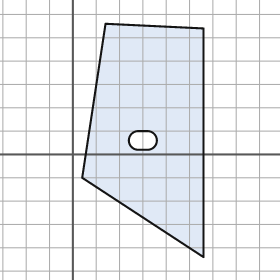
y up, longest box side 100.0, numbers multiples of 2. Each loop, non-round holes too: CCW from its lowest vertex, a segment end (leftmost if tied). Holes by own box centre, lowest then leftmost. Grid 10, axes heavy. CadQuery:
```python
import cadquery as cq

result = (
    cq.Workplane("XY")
    .moveTo(56.0, -44.0)
    .lineTo(56.0, 54.0)
    .lineTo(14.0, 56.0)
    .lineTo(4.0, -10.0)
    .close()
    .moveTo(28.0, 2.0)
    .lineTo(32.0, 2.0)
    .threePointArc((36.0, 6.0), (32.0, 10.0))
    .lineTo(28.0, 10.0)
    .threePointArc((24.0, 6.0), (28.0, 2.0))
    .close()
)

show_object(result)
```